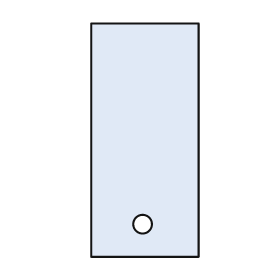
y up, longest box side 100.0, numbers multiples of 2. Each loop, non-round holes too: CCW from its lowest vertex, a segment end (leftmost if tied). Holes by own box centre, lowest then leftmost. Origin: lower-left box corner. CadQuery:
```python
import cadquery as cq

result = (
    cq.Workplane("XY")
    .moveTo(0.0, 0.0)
    .lineTo(46.0, 0.0)
    .lineTo(46.0, 100.0)
    .lineTo(0.0, 100.0)
    .close()
    .moveTo(22.0, 14.0)
    .circle(4.0)
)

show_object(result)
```